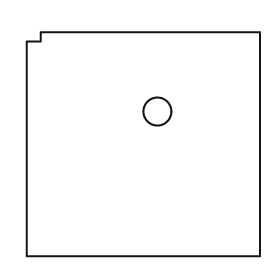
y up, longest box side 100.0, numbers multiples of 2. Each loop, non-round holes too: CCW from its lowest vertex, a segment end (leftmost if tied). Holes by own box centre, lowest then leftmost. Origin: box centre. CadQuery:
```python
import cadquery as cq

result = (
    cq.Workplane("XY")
    .moveTo(-50.0, -48.0)
    .lineTo(50.0, -48.0)
    .lineTo(50.0, 48.0)
    .lineTo(-44.0, 48.0)
    .lineTo(-44.0, 44.0)
    .lineTo(-50.0, 44.0)
    .close()
    .moveTo(6.0, 14.0)
    .circle(6.0)
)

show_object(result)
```